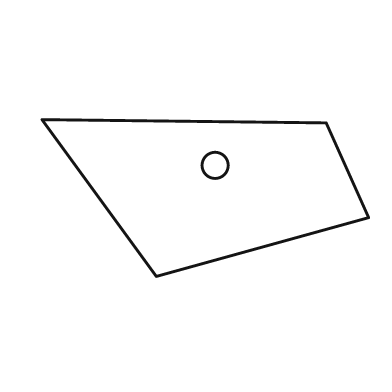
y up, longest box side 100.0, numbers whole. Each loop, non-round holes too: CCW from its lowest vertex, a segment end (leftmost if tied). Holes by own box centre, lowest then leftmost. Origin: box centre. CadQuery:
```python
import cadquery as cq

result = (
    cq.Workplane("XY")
    .moveTo(-15.0, -24.0)
    .lineTo(50.0, -6.0)
    .lineTo(37.0, 23.0)
    .lineTo(-50.0, 24.0)
    .close()
    .moveTo(3.0, 10.0)
    .circle(4.0)
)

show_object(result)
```